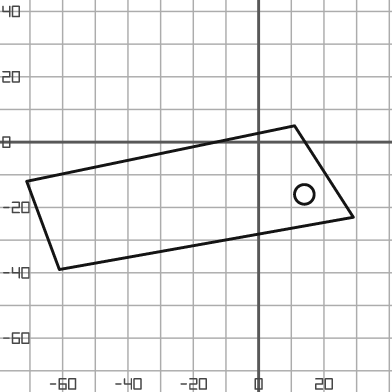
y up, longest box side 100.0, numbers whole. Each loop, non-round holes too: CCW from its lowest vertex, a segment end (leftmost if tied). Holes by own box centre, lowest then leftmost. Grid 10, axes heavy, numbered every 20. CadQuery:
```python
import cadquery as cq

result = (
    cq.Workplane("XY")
    .moveTo(-61.0, -39.0)
    .lineTo(29.0, -23.0)
    .lineTo(11.0, 5.0)
    .lineTo(-71.0, -12.0)
    .close()
    .moveTo(14.0, -16.0)
    .circle(3.0)
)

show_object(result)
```